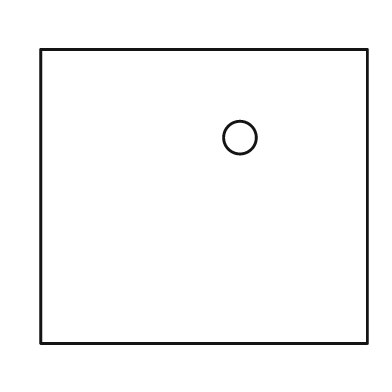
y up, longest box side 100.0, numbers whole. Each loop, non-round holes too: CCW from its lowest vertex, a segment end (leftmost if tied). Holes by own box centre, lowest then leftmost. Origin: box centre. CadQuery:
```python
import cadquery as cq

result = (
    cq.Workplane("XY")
    .moveTo(-50.0, -45.0)
    .lineTo(50.0, -45.0)
    .lineTo(50.0, 45.0)
    .lineTo(-50.0, 45.0)
    .close()
    .moveTo(11.0, 18.0)
    .circle(5.0)
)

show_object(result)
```